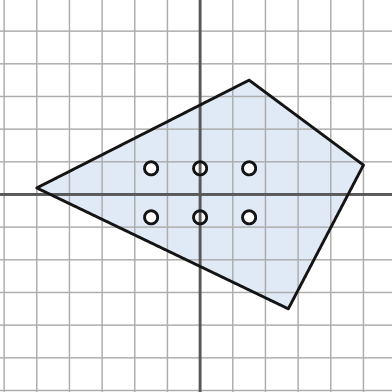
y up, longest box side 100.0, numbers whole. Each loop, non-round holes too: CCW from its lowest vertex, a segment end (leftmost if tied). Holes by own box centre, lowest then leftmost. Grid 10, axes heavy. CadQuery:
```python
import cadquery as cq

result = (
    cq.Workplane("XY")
    .moveTo(27.0, -35.0)
    .lineTo(50.0, 9.0)
    .lineTo(15.0, 35.0)
    .lineTo(-50.0, 2.0)
    .close()
    .moveTo(-15.0, -7.0)
    .circle(2.0)
    .moveTo(0.0, -7.0)
    .circle(2.0)
    .moveTo(15.0, -7.0)
    .circle(2.0)
    .moveTo(-15.0, 8.0)
    .circle(2.0)
    .moveTo(0.0, 8.0)
    .circle(2.0)
    .moveTo(15.0, 8.0)
    .circle(2.0)
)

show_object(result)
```